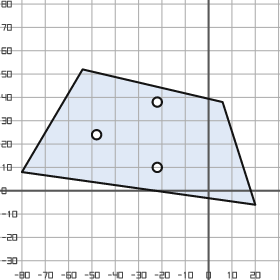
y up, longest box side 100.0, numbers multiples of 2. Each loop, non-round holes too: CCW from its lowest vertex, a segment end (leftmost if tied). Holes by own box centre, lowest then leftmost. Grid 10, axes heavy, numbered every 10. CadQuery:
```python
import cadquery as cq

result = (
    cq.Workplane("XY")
    .moveTo(20.0, -6.0)
    .lineTo(6.0, 38.0)
    .lineTo(-54.0, 52.0)
    .lineTo(-80.0, 8.0)
    .close()
    .moveTo(-22.0, 10.0)
    .circle(2.0)
    .moveTo(-48.0, 24.0)
    .circle(2.0)
    .moveTo(-22.0, 38.0)
    .circle(2.0)
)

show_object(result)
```